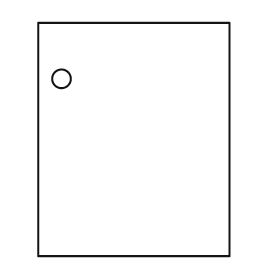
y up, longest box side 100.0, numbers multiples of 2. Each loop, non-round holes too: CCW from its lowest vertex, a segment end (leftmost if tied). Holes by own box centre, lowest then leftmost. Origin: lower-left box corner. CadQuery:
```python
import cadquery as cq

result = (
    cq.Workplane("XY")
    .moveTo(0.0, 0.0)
    .lineTo(82.0, 0.0)
    .lineTo(82.0, 100.0)
    .lineTo(0.0, 100.0)
    .close()
    .moveTo(10.0, 76.0)
    .circle(4.0)
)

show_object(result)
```